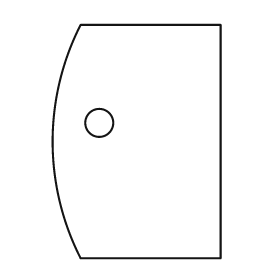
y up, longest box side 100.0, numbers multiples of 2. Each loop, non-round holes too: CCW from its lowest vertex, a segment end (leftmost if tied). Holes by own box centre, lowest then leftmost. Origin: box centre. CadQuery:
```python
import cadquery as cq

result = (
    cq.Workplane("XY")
    .moveTo(-24.0, -50.0)
    .lineTo(36.0, -50.0)
    .lineTo(36.0, 50.0)
    .lineTo(-24.0, 50.0)
    .threePointArc((-36.0, 0.0), (-24.0, -50.0))
    .close()
    .moveTo(-16.0, 8.0)
    .circle(6.0)
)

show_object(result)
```